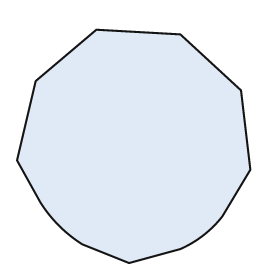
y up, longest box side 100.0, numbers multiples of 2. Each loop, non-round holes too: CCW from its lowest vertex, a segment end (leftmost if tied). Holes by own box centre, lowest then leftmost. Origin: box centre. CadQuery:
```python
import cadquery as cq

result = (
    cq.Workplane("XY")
    .moveTo(-2.0, -50.0)
    .lineTo(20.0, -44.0)
    .threePointArc((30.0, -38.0), (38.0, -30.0))
    .lineTo(50.0, -10.0)
    .lineTo(46.0, 24.0)
    .lineTo(20.0, 48.0)
    .lineTo(-16.0, 50.0)
    .lineTo(-42.0, 28.0)
    .lineTo(-50.0, -6.0)
    .lineTo(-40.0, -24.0)
    .threePointArc((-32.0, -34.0), (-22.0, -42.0))
    .close()
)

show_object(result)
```